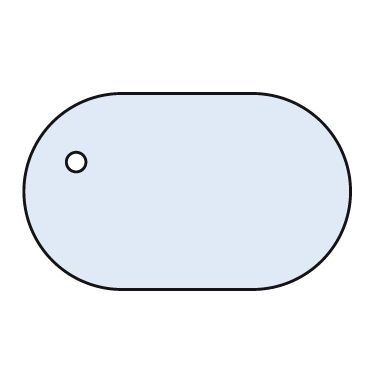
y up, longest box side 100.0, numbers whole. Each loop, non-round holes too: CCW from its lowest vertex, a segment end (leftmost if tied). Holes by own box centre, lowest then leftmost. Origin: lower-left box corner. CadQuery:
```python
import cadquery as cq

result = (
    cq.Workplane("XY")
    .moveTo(30.0, 0.0)
    .lineTo(70.0, 0.0)
    .threePointArc((100.0, 30.0), (70.0, 60.0))
    .lineTo(30.0, 60.0)
    .threePointArc((0.0, 30.0), (30.0, 0.0))
    .close()
    .moveTo(16.0, 39.0)
    .circle(3.0)
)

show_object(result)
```